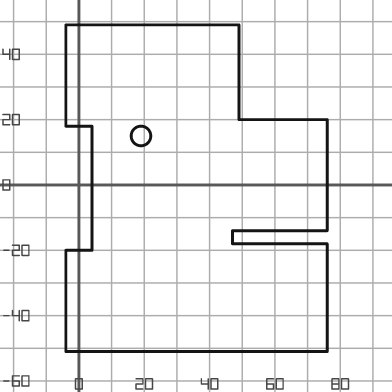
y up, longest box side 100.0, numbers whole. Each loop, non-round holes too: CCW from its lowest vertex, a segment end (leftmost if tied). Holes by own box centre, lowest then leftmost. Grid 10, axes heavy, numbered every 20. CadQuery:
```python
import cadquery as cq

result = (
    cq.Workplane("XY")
    .moveTo(-4.0, -51.0)
    .lineTo(76.0, -51.0)
    .lineTo(76.0, -18.0)
    .lineTo(47.0, -18.0)
    .lineTo(47.0, -14.0)
    .lineTo(76.0, -14.0)
    .lineTo(76.0, 20.0)
    .lineTo(49.0, 20.0)
    .lineTo(49.0, 49.0)
    .lineTo(-4.0, 49.0)
    .lineTo(-4.0, 18.0)
    .lineTo(4.0, 18.0)
    .lineTo(4.0, -20.0)
    .lineTo(-4.0, -20.0)
    .close()
    .moveTo(19.0, 15.0)
    .circle(3.0)
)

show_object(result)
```